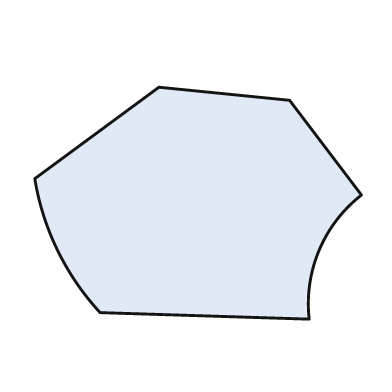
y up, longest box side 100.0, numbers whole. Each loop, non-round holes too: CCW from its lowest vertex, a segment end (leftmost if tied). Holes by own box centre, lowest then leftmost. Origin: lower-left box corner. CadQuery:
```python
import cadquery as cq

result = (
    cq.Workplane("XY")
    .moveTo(84.0, 0.0)
    .threePointArc((87.0, 21.0), (100.0, 38.0))
    .lineTo(78.0, 67.0)
    .lineTo(38.0, 71.0)
    .lineTo(0.0, 43.0)
    .threePointArc((7.0, 21.0), (20.0, 2.0))
    .close()
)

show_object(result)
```